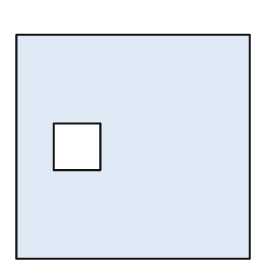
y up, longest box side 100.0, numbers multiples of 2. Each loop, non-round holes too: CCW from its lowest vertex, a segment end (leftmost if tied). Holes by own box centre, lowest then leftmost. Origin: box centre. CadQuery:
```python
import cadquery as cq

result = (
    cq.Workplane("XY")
    .moveTo(-50.0, -48.0)
    .lineTo(50.0, -48.0)
    .lineTo(50.0, 48.0)
    .lineTo(-50.0, 48.0)
    .close()
    .moveTo(-34.0, -10.0)
    .lineTo(-14.0, -10.0)
    .lineTo(-14.0, 10.0)
    .lineTo(-34.0, 10.0)
    .close()
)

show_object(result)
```